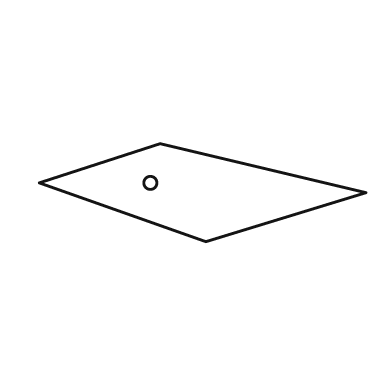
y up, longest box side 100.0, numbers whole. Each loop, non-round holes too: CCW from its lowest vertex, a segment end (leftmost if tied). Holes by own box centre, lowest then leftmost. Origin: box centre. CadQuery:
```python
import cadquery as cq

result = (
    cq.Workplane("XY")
    .moveTo(1.0, -15.0)
    .lineTo(50.0, 0.0)
    .lineTo(-13.0, 15.0)
    .lineTo(-50.0, 3.0)
    .close()
    .moveTo(-16.0, 3.0)
    .circle(2.0)
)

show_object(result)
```